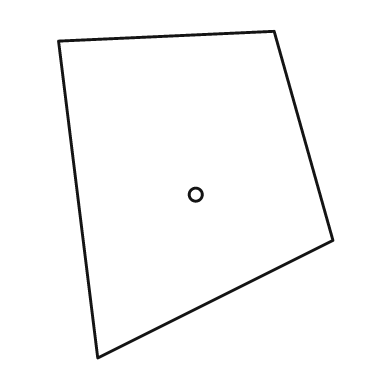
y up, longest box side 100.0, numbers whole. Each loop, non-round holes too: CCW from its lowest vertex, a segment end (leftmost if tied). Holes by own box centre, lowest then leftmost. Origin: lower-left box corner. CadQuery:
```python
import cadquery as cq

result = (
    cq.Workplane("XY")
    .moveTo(12.0, 0.0)
    .lineTo(84.0, 36.0)
    .lineTo(66.0, 100.0)
    .lineTo(0.0, 97.0)
    .close()
    .moveTo(42.0, 50.0)
    .circle(2.0)
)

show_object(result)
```